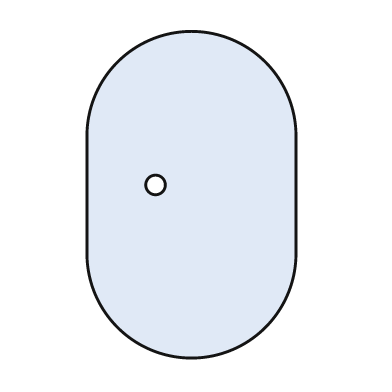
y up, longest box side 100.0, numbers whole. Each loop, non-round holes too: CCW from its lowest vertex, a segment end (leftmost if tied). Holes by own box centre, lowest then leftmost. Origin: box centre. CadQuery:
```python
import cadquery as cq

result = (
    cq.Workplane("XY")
    .moveTo(-32.0, -18.0)
    .threePointArc((0.0, -50.0), (32.0, -18.0))
    .lineTo(32.0, 18.0)
    .threePointArc((0.0, 50.0), (-32.0, 18.0))
    .close()
    .moveTo(-11.0, 3.0)
    .circle(3.0)
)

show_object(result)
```